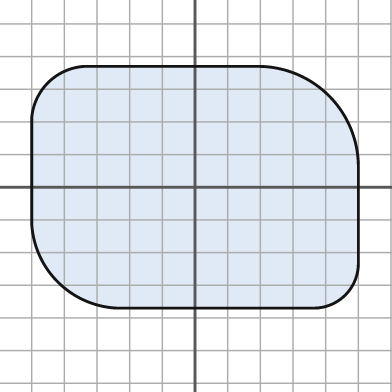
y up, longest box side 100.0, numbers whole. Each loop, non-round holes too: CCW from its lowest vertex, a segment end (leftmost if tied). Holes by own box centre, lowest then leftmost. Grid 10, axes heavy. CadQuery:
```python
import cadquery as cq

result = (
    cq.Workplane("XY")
    .moveTo(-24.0, -37.0)
    .lineTo(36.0, -37.0)
    .threePointArc((46.0, -33.0), (50.0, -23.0))
    .lineTo(50.0, 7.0)
    .threePointArc((41.0, 28.0), (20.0, 37.0))
    .lineTo(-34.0, 37.0)
    .threePointArc((-45.0, 32.0), (-50.0, 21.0))
    .lineTo(-50.0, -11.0)
    .threePointArc((-42.0, -29.0), (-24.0, -37.0))
    .close()
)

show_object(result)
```